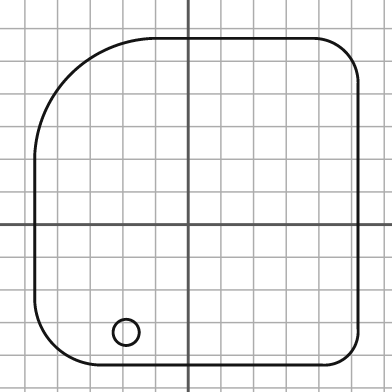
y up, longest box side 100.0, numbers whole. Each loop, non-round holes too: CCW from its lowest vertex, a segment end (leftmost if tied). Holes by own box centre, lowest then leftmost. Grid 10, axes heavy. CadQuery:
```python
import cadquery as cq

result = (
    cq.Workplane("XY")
    .moveTo(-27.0, -43.0)
    .lineTo(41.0, -43.0)
    .threePointArc((49.0, -40.0), (52.0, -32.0))
    .lineTo(52.0, 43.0)
    .threePointArc((48.0, 53.0), (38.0, 57.0))
    .lineTo(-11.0, 57.0)
    .threePointArc((-36.0, 46.0), (-47.0, 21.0))
    .lineTo(-47.0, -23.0)
    .threePointArc((-41.0, -37.0), (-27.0, -43.0))
    .close()
    .moveTo(-19.0, -33.0)
    .circle(4.0)
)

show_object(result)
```